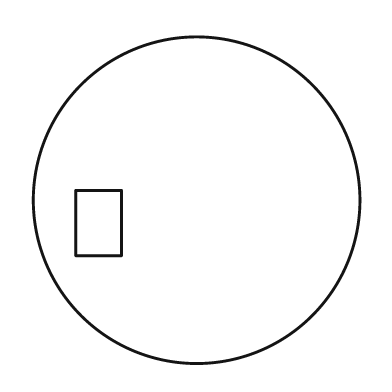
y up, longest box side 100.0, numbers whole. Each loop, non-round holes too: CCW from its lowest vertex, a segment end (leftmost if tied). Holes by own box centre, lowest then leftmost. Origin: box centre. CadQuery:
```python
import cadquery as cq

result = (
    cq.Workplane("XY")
    .moveTo(0.0, 0.0)
    .circle(50.0)
    .moveTo(-37.0, -17.0)
    .lineTo(-23.0, -17.0)
    .lineTo(-23.0, 3.0)
    .lineTo(-37.0, 3.0)
    .close()
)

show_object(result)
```